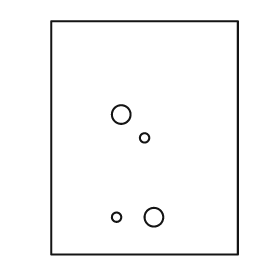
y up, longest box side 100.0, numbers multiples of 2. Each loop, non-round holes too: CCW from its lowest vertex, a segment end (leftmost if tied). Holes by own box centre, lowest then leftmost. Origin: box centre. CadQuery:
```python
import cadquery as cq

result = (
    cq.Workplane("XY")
    .moveTo(-40.0, -50.0)
    .lineTo(40.0, -50.0)
    .lineTo(40.0, 50.0)
    .lineTo(-40.0, 50.0)
    .close()
    .moveTo(-12.0, -34.0)
    .circle(2.0)
    .moveTo(4.0, -34.0)
    .circle(4.0)
    .moveTo(0.0, 0.0)
    .circle(2.0)
    .moveTo(-10.0, 10.0)
    .circle(4.0)
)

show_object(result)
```